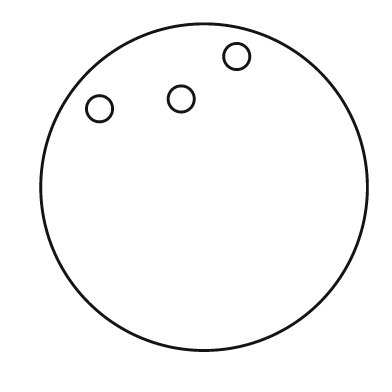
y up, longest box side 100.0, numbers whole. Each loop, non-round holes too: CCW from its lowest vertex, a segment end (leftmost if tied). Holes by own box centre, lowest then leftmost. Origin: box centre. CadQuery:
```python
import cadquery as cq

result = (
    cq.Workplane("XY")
    .moveTo(0.0, 0.0)
    .circle(50.0)
    .moveTo(-32.0, 24.0)
    .circle(4.0)
    .moveTo(-7.0, 27.0)
    .circle(4.0)
    .moveTo(10.0, 40.0)
    .circle(4.0)
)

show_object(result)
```